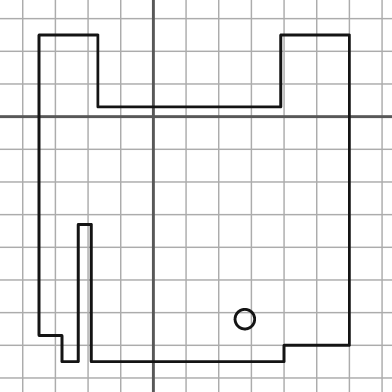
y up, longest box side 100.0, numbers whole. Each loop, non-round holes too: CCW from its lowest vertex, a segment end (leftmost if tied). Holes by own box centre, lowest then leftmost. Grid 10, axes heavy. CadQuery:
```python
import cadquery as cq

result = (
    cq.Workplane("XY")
    .moveTo(-28.0, -75.0)
    .lineTo(-23.0, -75.0)
    .lineTo(-23.0, -33.0)
    .lineTo(-19.0, -33.0)
    .lineTo(-19.0, -75.0)
    .lineTo(40.0, -75.0)
    .lineTo(40.0, -70.0)
    .lineTo(60.0, -70.0)
    .lineTo(60.0, 25.0)
    .lineTo(39.0, 25.0)
    .lineTo(39.0, 3.0)
    .lineTo(-17.0, 3.0)
    .lineTo(-17.0, 25.0)
    .lineTo(-35.0, 25.0)
    .lineTo(-35.0, -67.0)
    .lineTo(-28.0, -67.0)
    .close()
    .moveTo(28.0, -62.0)
    .circle(3.0)
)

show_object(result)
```